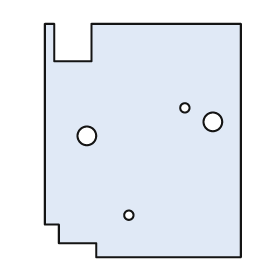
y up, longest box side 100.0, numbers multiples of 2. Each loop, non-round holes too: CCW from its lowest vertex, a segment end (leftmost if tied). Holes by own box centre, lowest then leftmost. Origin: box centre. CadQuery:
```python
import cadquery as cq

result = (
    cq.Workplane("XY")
    .moveTo(-20.0, -50.0)
    .lineTo(42.0, -50.0)
    .lineTo(42.0, 50.0)
    .lineTo(-22.0, 50.0)
    .lineTo(-22.0, 34.0)
    .lineTo(-38.0, 34.0)
    .lineTo(-38.0, 50.0)
    .lineTo(-42.0, 50.0)
    .lineTo(-42.0, -36.0)
    .lineTo(-36.0, -36.0)
    .lineTo(-36.0, -44.0)
    .lineTo(-20.0, -44.0)
    .close()
    .moveTo(-6.0, -32.0)
    .circle(2.0)
    .moveTo(-24.0, 2.0)
    .circle(4.0)
    .moveTo(30.0, 8.0)
    .circle(4.0)
    .moveTo(18.0, 14.0)
    .circle(2.0)
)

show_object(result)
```